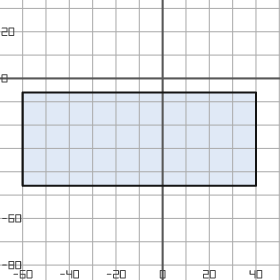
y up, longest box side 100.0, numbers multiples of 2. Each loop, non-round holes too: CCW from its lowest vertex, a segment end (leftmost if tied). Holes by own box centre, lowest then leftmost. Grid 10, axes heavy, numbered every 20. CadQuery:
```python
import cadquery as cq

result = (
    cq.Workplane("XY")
    .moveTo(-60.0, -46.0)
    .lineTo(40.0, -46.0)
    .lineTo(40.0, -6.0)
    .lineTo(-60.0, -6.0)
    .close()
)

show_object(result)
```